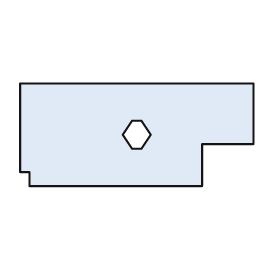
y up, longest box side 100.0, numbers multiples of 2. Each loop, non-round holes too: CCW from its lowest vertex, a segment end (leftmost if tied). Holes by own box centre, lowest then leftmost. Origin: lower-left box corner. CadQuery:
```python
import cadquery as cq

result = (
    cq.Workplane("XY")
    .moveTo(4.0, 0.0)
    .lineTo(78.0, 0.0)
    .lineTo(78.0, 18.0)
    .lineTo(100.0, 18.0)
    .lineTo(100.0, 44.0)
    .lineTo(0.0, 44.0)
    .lineTo(0.0, 6.0)
    .lineTo(4.0, 6.0)
    .close()
    .moveTo(48.0, 16.0)
    .lineTo(52.0, 16.0)
    .lineTo(56.0, 22.0)
    .lineTo(52.0, 28.0)
    .lineTo(48.0, 28.0)
    .lineTo(44.0, 22.0)
    .close()
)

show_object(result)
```